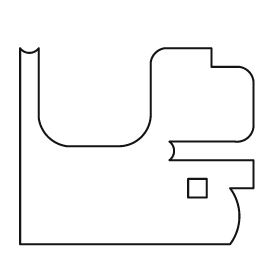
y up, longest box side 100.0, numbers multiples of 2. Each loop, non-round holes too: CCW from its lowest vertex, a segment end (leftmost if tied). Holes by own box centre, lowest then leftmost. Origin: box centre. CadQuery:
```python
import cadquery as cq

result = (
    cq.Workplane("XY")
    .moveTo(-50.0, -42.0)
    .lineTo(40.0, -42.0)
    .threePointArc((44.0, -30.0), (40.0, -18.0))
    .lineTo(50.0, -18.0)
    .lineTo(50.0, -6.0)
    .lineTo(14.0, -6.0)
    .threePointArc((16.0, -2.0), (14.0, 2.0))
    .lineTo(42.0, 2.0)
    .threePointArc((48.0, 4.0), (50.0, 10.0))
    .lineTo(50.0, 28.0)
    .threePointArc((48.0, 32.0), (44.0, 34.0))
    .lineTo(32.0, 34.0)
    .lineTo(32.0, 42.0)
    .lineTo(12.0, 42.0)
    .threePointArc((8.0, 40.0), (6.0, 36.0))
    .lineTo(6.0, 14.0)
    .threePointArc((2.0, 4.0), (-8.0, 0.0))
    .lineTo(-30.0, 0.0)
    .threePointArc((-38.0, 4.0), (-42.0, 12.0))
    .lineTo(-42.0, 42.0)
    .threePointArc((-46.0, 40.0), (-50.0, 42.0))
    .close()
    .moveTo(22.0, -22.0)
    .lineTo(30.0, -22.0)
    .lineTo(30.0, -14.0)
    .lineTo(22.0, -14.0)
    .close()
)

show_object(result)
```